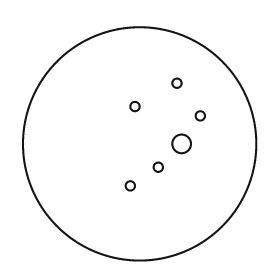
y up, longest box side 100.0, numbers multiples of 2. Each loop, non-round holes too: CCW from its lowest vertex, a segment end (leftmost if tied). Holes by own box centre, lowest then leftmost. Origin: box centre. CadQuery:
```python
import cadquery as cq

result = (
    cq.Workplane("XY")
    .moveTo(0.0, 0.0)
    .circle(50.0)
    .moveTo(-4.0, -18.0)
    .circle(2.0)
    .moveTo(8.0, -10.0)
    .circle(2.0)
    .moveTo(18.0, 0.0)
    .circle(4.0)
    .moveTo(26.0, 12.0)
    .circle(2.0)
    .moveTo(-2.0, 16.0)
    .circle(2.0)
    .moveTo(16.0, 26.0)
    .circle(2.0)
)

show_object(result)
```